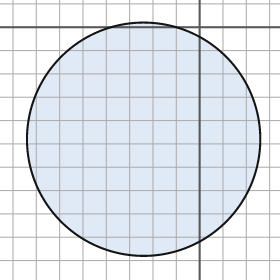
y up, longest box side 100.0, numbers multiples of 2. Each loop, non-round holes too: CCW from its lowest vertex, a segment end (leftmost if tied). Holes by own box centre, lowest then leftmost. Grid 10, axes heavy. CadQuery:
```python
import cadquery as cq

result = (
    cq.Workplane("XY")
    .moveTo(-24.0, -48.0)
    .circle(50.0)
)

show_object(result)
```